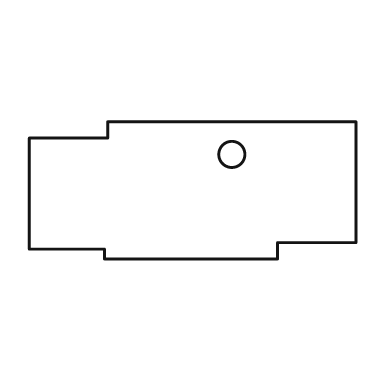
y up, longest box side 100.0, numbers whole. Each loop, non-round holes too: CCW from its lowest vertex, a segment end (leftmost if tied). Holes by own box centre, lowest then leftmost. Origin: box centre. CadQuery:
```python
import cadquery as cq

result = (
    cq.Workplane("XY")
    .moveTo(-27.0, -21.0)
    .lineTo(26.0, -21.0)
    .lineTo(26.0, -16.0)
    .lineTo(50.0, -16.0)
    .lineTo(50.0, 21.0)
    .lineTo(-26.0, 21.0)
    .lineTo(-26.0, 16.0)
    .lineTo(-50.0, 16.0)
    .lineTo(-50.0, -18.0)
    .lineTo(-27.0, -18.0)
    .close()
    .moveTo(12.0, 11.0)
    .circle(4.0)
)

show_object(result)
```